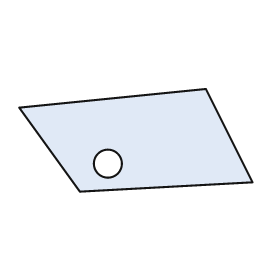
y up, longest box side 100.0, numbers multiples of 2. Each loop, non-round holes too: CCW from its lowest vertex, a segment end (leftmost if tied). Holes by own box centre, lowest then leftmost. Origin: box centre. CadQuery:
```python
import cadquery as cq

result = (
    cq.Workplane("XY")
    .moveTo(-24.0, -22.0)
    .lineTo(50.0, -18.0)
    .lineTo(30.0, 22.0)
    .lineTo(-50.0, 14.0)
    .close()
    .moveTo(-12.0, -10.0)
    .circle(6.0)
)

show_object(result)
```